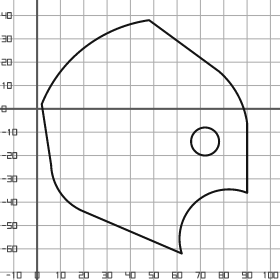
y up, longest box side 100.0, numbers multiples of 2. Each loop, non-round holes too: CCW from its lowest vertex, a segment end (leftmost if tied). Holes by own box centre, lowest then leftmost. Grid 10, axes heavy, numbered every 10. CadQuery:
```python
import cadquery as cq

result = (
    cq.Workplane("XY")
    .moveTo(62.0, -62.0)
    .threePointArc((68.0, -40.0), (90.0, -36.0))
    .lineTo(90.0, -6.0)
    .threePointArc((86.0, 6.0), (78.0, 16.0))
    .lineTo(48.0, 38.0)
    .threePointArc((20.0, 26.0), (2.0, 2.0))
    .lineTo(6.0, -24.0)
    .threePointArc((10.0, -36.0), (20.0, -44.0))
    .close()
    .moveTo(72.0, -14.0)
    .circle(6.0)
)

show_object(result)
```